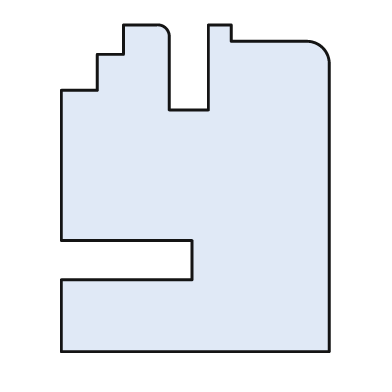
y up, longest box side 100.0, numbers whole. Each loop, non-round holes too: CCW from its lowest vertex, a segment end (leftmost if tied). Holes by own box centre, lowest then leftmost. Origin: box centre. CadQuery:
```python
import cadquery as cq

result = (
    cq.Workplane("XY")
    .moveTo(-41.0, -50.0)
    .lineTo(41.0, -50.0)
    .lineTo(41.0, 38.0)
    .threePointArc((39.0, 43.0), (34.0, 45.0))
    .lineTo(11.0, 45.0)
    .lineTo(11.0, 50.0)
    .lineTo(4.0, 50.0)
    .lineTo(4.0, 24.0)
    .lineTo(-8.0, 24.0)
    .lineTo(-8.0, 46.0)
    .threePointArc((-9.0, 49.0), (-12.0, 50.0))
    .lineTo(-22.0, 50.0)
    .lineTo(-22.0, 41.0)
    .lineTo(-30.0, 41.0)
    .lineTo(-30.0, 30.0)
    .lineTo(-41.0, 30.0)
    .lineTo(-41.0, -16.0)
    .lineTo(-1.0, -16.0)
    .lineTo(-1.0, -28.0)
    .lineTo(-41.0, -28.0)
    .close()
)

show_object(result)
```